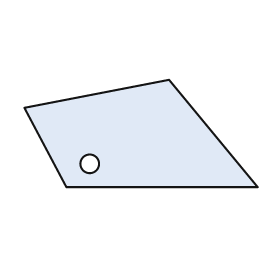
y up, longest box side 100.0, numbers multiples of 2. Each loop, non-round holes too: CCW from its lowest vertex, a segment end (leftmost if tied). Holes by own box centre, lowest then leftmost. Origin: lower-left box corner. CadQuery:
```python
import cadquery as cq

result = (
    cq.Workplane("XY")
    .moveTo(18.0, 0.0)
    .lineTo(100.0, 0.0)
    .lineTo(62.0, 46.0)
    .lineTo(0.0, 34.0)
    .close()
    .moveTo(28.0, 10.0)
    .circle(4.0)
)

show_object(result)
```